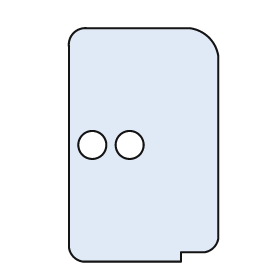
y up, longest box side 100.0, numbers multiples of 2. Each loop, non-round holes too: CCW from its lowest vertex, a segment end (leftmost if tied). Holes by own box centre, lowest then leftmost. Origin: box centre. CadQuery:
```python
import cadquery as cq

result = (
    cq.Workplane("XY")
    .moveTo(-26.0, -50.0)
    .lineTo(16.0, -50.0)
    .lineTo(16.0, -46.0)
    .lineTo(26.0, -46.0)
    .threePointArc((30.0, -44.0), (32.0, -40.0))
    .lineTo(32.0, 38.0)
    .threePointArc((28.0, 46.0), (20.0, 50.0))
    .lineTo(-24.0, 50.0)
    .threePointArc((-30.0, 48.0), (-32.0, 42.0))
    .lineTo(-32.0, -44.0)
    .threePointArc((-30.0, -48.0), (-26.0, -50.0))
    .close()
    .moveTo(-22.0, 0.0)
    .circle(6.0)
    .moveTo(-6.0, 0.0)
    .circle(6.0)
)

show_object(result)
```